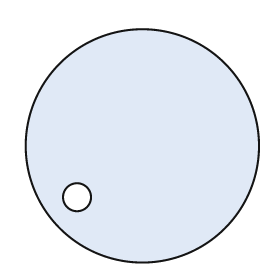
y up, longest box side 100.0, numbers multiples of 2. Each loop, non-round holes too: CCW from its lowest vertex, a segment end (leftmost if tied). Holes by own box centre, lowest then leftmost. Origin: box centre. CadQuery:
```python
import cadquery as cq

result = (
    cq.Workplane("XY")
    .moveTo(0.0, 0.0)
    .circle(50.0)
    .moveTo(-28.0, -22.0)
    .circle(6.0)
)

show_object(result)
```